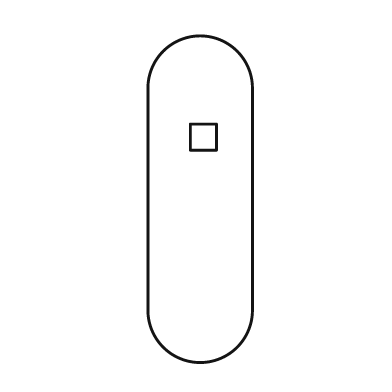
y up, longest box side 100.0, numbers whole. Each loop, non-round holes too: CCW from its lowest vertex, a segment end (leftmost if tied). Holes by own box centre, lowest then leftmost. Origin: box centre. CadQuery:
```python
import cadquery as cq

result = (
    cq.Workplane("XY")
    .moveTo(-16.0, -34.0)
    .threePointArc((0.0, -50.0), (16.0, -34.0))
    .lineTo(16.0, 34.0)
    .threePointArc((0.0, 50.0), (-16.0, 34.0))
    .close()
    .moveTo(-3.0, 15.0)
    .lineTo(5.0, 15.0)
    .lineTo(5.0, 23.0)
    .lineTo(-3.0, 23.0)
    .close()
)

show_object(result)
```